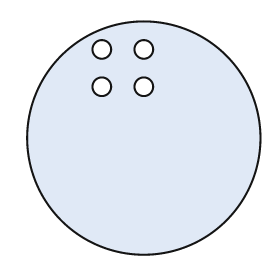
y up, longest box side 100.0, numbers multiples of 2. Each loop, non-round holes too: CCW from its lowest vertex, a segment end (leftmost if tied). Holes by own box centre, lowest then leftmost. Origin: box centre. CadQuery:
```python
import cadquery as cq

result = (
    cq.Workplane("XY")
    .moveTo(0.0, 0.0)
    .circle(50.0)
    .moveTo(-18.0, 22.0)
    .circle(4.0)
    .moveTo(0.0, 22.0)
    .circle(4.0)
    .moveTo(-18.0, 38.0)
    .circle(4.0)
    .moveTo(0.0, 38.0)
    .circle(4.0)
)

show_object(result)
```